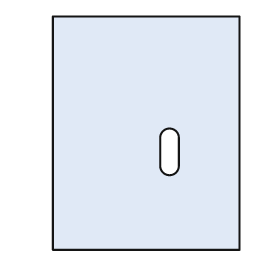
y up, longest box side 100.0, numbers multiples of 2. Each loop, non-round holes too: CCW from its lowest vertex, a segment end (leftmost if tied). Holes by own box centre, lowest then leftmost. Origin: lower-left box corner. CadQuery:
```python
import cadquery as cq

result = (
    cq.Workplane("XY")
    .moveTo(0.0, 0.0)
    .lineTo(80.0, 0.0)
    .lineTo(80.0, 100.0)
    .lineTo(0.0, 100.0)
    .close()
    .moveTo(46.0, 36.0)
    .threePointArc((50.0, 32.0), (54.0, 36.0))
    .lineTo(54.0, 48.0)
    .threePointArc((50.0, 52.0), (46.0, 48.0))
    .close()
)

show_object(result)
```